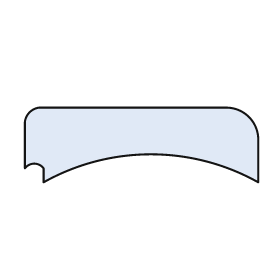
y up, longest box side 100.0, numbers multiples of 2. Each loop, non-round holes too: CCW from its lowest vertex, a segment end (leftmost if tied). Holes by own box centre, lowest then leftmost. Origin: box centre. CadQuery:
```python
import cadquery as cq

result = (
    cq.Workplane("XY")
    .moveTo(-42.0, -16.0)
    .threePointArc((4.0, -4.0), (50.0, -16.0))
    .lineTo(50.0, 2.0)
    .threePointArc((46.0, 12.0), (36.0, 16.0))
    .lineTo(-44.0, 16.0)
    .threePointArc((-48.0, 14.0), (-50.0, 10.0))
    .lineTo(-50.0, -10.0)
    .threePointArc((-46.0, -8.0), (-42.0, -10.0))
    .close()
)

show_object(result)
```